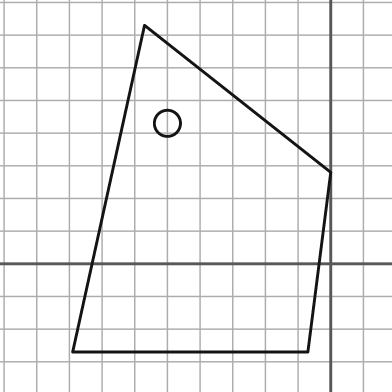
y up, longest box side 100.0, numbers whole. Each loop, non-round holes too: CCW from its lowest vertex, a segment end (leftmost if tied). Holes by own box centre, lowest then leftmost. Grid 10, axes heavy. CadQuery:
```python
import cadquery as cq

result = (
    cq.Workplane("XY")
    .moveTo(-79.0, -27.0)
    .lineTo(-7.0, -27.0)
    .lineTo(0.0, 28.0)
    .lineTo(-57.0, 73.0)
    .close()
    .moveTo(-50.0, 43.0)
    .circle(4.0)
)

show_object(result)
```